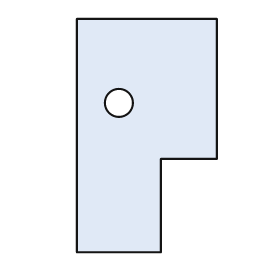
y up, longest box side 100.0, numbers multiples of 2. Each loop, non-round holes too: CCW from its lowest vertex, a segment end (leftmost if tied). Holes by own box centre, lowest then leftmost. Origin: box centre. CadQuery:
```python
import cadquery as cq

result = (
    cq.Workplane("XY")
    .moveTo(-30.0, -50.0)
    .lineTo(6.0, -50.0)
    .lineTo(6.0, -10.0)
    .lineTo(30.0, -10.0)
    .lineTo(30.0, 50.0)
    .lineTo(-30.0, 50.0)
    .close()
    .moveTo(-12.0, 14.0)
    .circle(6.0)
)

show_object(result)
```